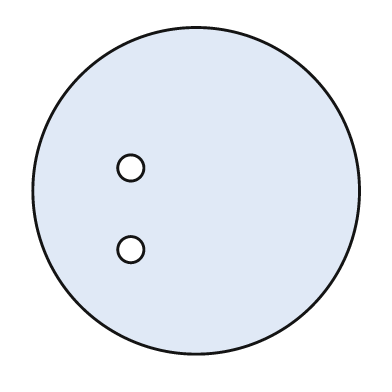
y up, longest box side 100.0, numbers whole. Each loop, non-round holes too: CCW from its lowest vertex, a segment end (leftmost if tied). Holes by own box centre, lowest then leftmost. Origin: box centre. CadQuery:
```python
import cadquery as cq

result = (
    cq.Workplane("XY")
    .moveTo(0.0, 0.0)
    .circle(50.0)
    .moveTo(-20.0, -18.0)
    .circle(4.0)
    .moveTo(-20.0, 7.0)
    .circle(4.0)
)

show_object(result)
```